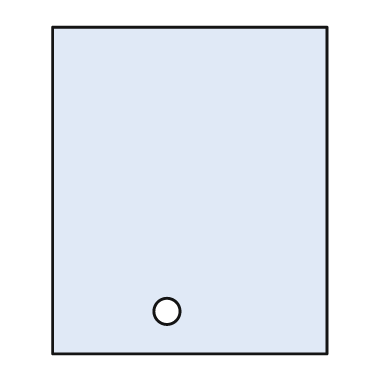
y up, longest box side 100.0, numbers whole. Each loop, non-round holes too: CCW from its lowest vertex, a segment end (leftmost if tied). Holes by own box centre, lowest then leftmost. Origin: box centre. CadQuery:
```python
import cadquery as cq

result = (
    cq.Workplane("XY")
    .moveTo(-42.0, -50.0)
    .lineTo(42.0, -50.0)
    .lineTo(42.0, 50.0)
    .lineTo(-42.0, 50.0)
    .close()
    .moveTo(-7.0, -37.0)
    .circle(4.0)
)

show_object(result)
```